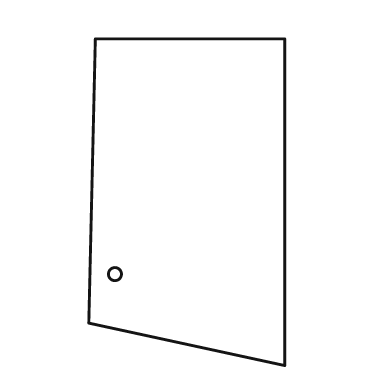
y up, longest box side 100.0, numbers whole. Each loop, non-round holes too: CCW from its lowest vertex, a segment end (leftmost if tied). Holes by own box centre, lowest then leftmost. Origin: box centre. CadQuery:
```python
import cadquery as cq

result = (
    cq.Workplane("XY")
    .moveTo(30.0, -50.0)
    .lineTo(30.0, 50.0)
    .lineTo(-28.0, 50.0)
    .lineTo(-30.0, -37.0)
    .close()
    .moveTo(-22.0, -22.0)
    .circle(2.0)
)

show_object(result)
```